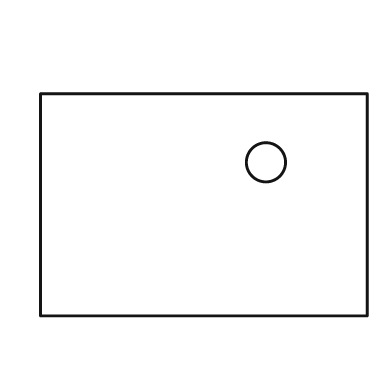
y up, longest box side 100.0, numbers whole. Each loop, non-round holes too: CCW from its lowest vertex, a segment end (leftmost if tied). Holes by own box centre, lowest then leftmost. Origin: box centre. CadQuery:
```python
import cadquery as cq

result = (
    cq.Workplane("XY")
    .moveTo(-50.0, -34.0)
    .lineTo(50.0, -34.0)
    .lineTo(50.0, 34.0)
    .lineTo(-50.0, 34.0)
    .close()
    .moveTo(19.0, 13.0)
    .circle(6.0)
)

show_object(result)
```